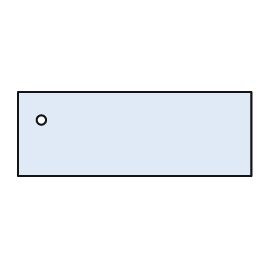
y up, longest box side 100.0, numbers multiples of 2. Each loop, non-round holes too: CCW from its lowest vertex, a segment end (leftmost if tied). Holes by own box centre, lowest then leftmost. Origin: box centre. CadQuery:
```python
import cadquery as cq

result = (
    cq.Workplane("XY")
    .moveTo(-50.0, -18.0)
    .lineTo(50.0, -18.0)
    .lineTo(50.0, 18.0)
    .lineTo(-50.0, 18.0)
    .close()
    .moveTo(-40.0, 6.0)
    .circle(2.0)
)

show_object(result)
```